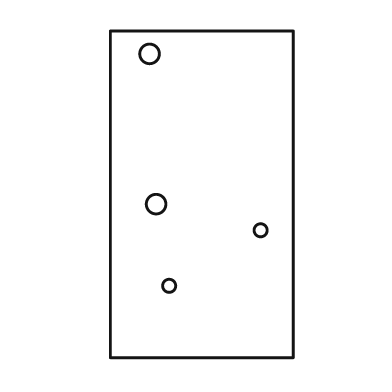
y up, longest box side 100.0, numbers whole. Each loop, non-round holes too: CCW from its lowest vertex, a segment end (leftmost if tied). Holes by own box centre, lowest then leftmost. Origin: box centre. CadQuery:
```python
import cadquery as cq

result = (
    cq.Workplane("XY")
    .moveTo(-28.0, -50.0)
    .lineTo(28.0, -50.0)
    .lineTo(28.0, 50.0)
    .lineTo(-28.0, 50.0)
    .close()
    .moveTo(-10.0, -28.0)
    .circle(2.0)
    .moveTo(18.0, -11.0)
    .circle(2.0)
    .moveTo(-14.0, -3.0)
    .circle(3.0)
    .moveTo(-16.0, 43.0)
    .circle(3.0)
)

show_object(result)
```